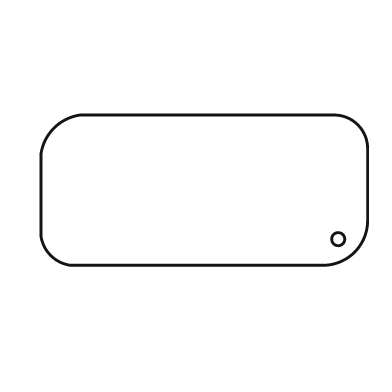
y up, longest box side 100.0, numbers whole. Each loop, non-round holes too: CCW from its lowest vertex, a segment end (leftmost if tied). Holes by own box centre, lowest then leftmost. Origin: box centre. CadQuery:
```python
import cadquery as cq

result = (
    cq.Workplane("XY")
    .moveTo(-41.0, -23.0)
    .lineTo(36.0, -23.0)
    .threePointArc((46.0, -19.0), (50.0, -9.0))
    .lineTo(50.0, 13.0)
    .threePointArc((47.0, 20.0), (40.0, 23.0))
    .lineTo(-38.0, 23.0)
    .threePointArc((-46.0, 19.0), (-50.0, 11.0))
    .lineTo(-50.0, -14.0)
    .threePointArc((-47.0, -20.0), (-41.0, -23.0))
    .close()
    .moveTo(41.0, -15.0)
    .circle(2.0)
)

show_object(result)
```